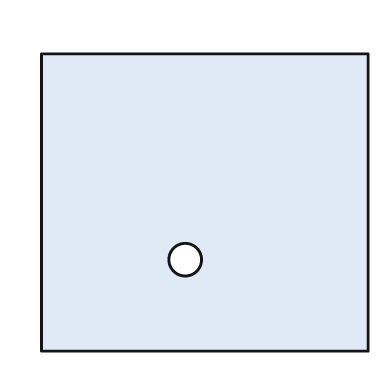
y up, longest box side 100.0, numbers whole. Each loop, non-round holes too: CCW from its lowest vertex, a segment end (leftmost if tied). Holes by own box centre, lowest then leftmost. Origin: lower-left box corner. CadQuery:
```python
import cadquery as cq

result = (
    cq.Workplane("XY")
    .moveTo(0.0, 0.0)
    .lineTo(100.0, 0.0)
    .lineTo(100.0, 91.0)
    .lineTo(0.0, 91.0)
    .close()
    .moveTo(44.0, 28.0)
    .circle(5.0)
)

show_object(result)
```